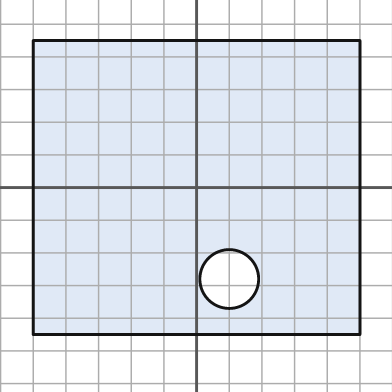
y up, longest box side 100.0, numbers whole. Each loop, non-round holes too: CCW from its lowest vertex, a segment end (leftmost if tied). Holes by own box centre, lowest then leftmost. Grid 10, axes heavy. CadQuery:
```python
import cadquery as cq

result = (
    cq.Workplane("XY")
    .moveTo(-50.0, -45.0)
    .lineTo(50.0, -45.0)
    .lineTo(50.0, 45.0)
    .lineTo(-50.0, 45.0)
    .close()
    .moveTo(10.0, -28.0)
    .circle(9.0)
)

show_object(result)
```